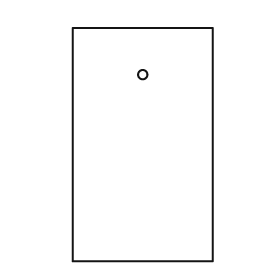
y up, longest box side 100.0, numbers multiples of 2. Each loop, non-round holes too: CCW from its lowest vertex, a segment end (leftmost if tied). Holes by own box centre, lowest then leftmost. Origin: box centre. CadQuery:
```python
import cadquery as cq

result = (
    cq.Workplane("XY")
    .moveTo(-30.0, -50.0)
    .lineTo(30.0, -50.0)
    .lineTo(30.0, 50.0)
    .lineTo(-30.0, 50.0)
    .close()
    .moveTo(0.0, 30.0)
    .circle(2.0)
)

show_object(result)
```